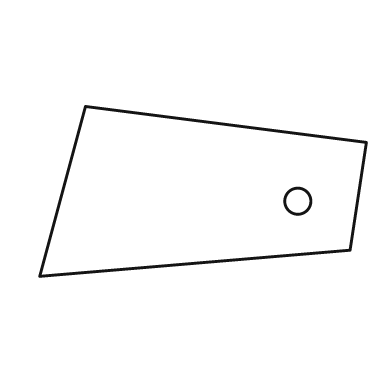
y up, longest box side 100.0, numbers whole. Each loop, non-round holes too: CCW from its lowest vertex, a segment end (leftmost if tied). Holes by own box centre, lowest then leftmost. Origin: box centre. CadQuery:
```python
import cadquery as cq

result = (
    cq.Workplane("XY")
    .moveTo(-50.0, -26.0)
    .lineTo(45.0, -18.0)
    .lineTo(50.0, 15.0)
    .lineTo(-36.0, 26.0)
    .close()
    .moveTo(29.0, -3.0)
    .circle(4.0)
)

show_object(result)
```